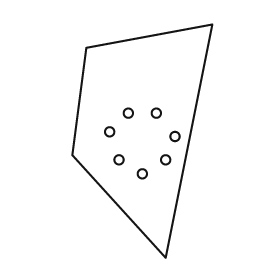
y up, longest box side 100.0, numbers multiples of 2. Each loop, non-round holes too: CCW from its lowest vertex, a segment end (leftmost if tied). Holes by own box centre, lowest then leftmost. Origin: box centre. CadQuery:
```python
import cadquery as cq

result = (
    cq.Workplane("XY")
    .moveTo(10.0, -50.0)
    .lineTo(30.0, 50.0)
    .lineTo(-24.0, 40.0)
    .lineTo(-30.0, -6.0)
    .close()
    .moveTo(0.0, -14.0)
    .circle(2.0)
    .moveTo(-10.0, -8.0)
    .circle(2.0)
    .moveTo(10.0, -8.0)
    .circle(2.0)
    .moveTo(14.0, 2.0)
    .circle(2.0)
    .moveTo(-14.0, 4.0)
    .circle(2.0)
    .moveTo(-6.0, 12.0)
    .circle(2.0)
    .moveTo(6.0, 12.0)
    .circle(2.0)
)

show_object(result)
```